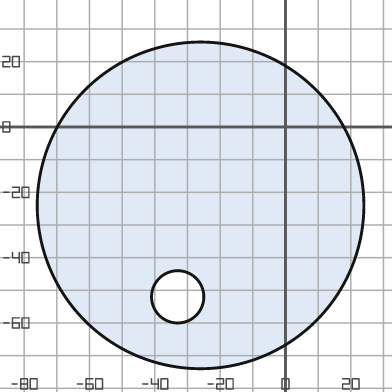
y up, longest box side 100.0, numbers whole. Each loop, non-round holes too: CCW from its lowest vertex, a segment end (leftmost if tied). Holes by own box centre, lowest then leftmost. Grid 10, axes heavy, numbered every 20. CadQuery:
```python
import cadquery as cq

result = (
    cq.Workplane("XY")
    .moveTo(-26.0, -24.0)
    .circle(50.0)
    .moveTo(-33.0, -52.0)
    .circle(8.0)
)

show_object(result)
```